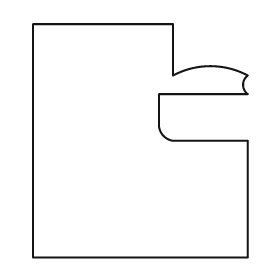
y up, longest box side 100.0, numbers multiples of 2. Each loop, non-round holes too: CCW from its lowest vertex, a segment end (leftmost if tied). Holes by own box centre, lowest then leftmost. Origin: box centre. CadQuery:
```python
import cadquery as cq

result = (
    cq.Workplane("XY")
    .moveTo(-46.0, -50.0)
    .lineTo(46.0, -50.0)
    .lineTo(46.0, 0.0)
    .lineTo(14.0, 0.0)
    .threePointArc((10.0, 2.0), (8.0, 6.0))
    .lineTo(8.0, 20.0)
    .lineTo(46.0, 20.0)
    .threePointArc((44.0, 24.0), (46.0, 28.0))
    .threePointArc((30.0, 32.0), (14.0, 28.0))
    .lineTo(14.0, 50.0)
    .lineTo(-46.0, 50.0)
    .close()
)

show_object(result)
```